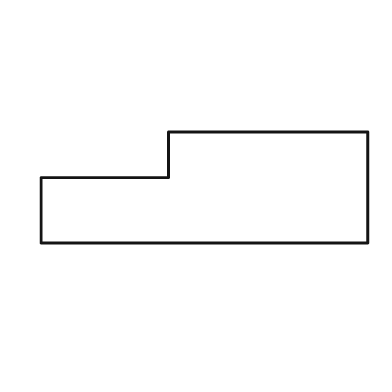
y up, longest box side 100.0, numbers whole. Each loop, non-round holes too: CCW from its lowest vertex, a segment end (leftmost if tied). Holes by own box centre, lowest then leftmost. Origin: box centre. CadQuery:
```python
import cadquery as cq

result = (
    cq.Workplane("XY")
    .moveTo(-50.0, -17.0)
    .lineTo(50.0, -17.0)
    .lineTo(50.0, 17.0)
    .lineTo(-11.0, 17.0)
    .lineTo(-11.0, 3.0)
    .lineTo(-50.0, 3.0)
    .close()
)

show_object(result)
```